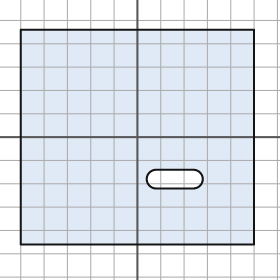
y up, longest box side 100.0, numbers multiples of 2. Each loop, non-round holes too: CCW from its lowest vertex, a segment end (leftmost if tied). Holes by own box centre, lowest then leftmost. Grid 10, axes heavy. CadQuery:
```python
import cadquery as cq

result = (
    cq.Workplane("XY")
    .moveTo(-50.0, -46.0)
    .lineTo(50.0, -46.0)
    .lineTo(50.0, 46.0)
    .lineTo(-50.0, 46.0)
    .close()
    .moveTo(8.0, -22.0)
    .lineTo(24.0, -22.0)
    .threePointArc((28.0, -18.0), (24.0, -14.0))
    .lineTo(8.0, -14.0)
    .threePointArc((4.0, -18.0), (8.0, -22.0))
    .close()
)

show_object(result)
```